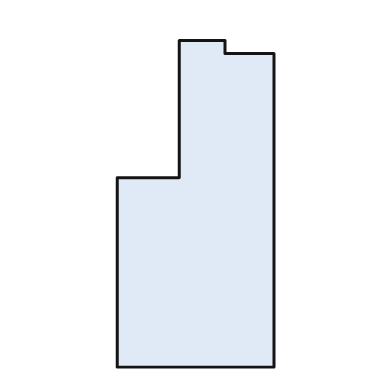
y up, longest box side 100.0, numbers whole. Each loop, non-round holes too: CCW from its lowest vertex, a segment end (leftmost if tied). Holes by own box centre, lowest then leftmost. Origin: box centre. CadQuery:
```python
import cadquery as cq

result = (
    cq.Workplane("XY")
    .moveTo(-24.0, -50.0)
    .lineTo(24.0, -50.0)
    .lineTo(24.0, 46.0)
    .lineTo(9.0, 46.0)
    .lineTo(9.0, 50.0)
    .lineTo(-5.0, 50.0)
    .lineTo(-5.0, 8.0)
    .lineTo(-24.0, 8.0)
    .close()
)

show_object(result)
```